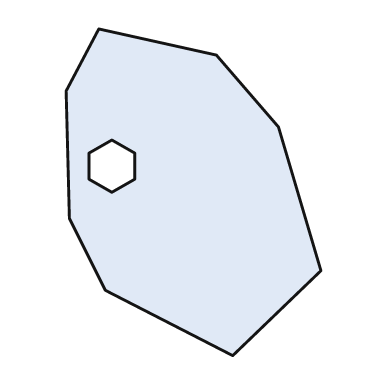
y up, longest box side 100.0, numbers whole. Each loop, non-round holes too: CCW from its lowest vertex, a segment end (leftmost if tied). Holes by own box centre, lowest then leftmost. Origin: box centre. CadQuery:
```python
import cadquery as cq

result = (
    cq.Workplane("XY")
    .moveTo(12.0, -50.0)
    .lineTo(39.0, -24.0)
    .lineTo(26.0, 20.0)
    .lineTo(7.0, 42.0)
    .lineTo(-29.0, 50.0)
    .lineTo(-39.0, 31.0)
    .lineTo(-38.0, -8.0)
    .lineTo(-27.0, -30.0)
    .close()
    .moveTo(-25.0, 0.0)
    .lineTo(-18.0, 4.0)
    .lineTo(-18.0, 12.0)
    .lineTo(-25.0, 16.0)
    .lineTo(-32.0, 12.0)
    .lineTo(-32.0, 4.0)
    .close()
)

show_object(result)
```